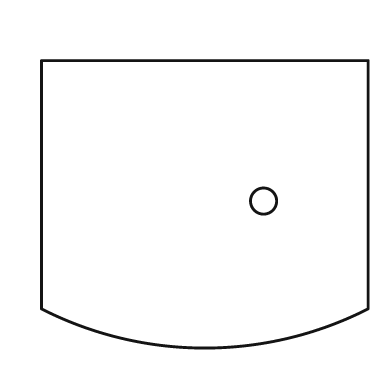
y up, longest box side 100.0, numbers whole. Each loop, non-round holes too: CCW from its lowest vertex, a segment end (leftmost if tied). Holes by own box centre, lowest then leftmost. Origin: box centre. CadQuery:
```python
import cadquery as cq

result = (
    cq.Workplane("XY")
    .moveTo(-50.0, -32.0)
    .threePointArc((0.0, -44.0), (50.0, -32.0))
    .lineTo(50.0, 44.0)
    .lineTo(-50.0, 44.0)
    .close()
    .moveTo(18.0, 1.0)
    .circle(4.0)
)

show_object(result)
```